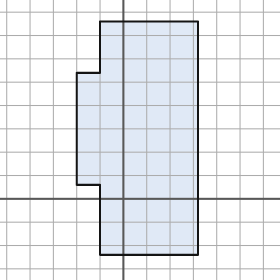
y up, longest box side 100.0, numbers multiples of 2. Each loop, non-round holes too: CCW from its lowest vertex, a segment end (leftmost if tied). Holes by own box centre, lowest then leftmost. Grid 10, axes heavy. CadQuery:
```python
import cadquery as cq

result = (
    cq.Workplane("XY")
    .moveTo(-10.0, -24.0)
    .lineTo(32.0, -24.0)
    .lineTo(32.0, 76.0)
    .lineTo(-10.0, 76.0)
    .lineTo(-10.0, 54.0)
    .lineTo(-20.0, 54.0)
    .lineTo(-20.0, 6.0)
    .lineTo(-10.0, 6.0)
    .close()
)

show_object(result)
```